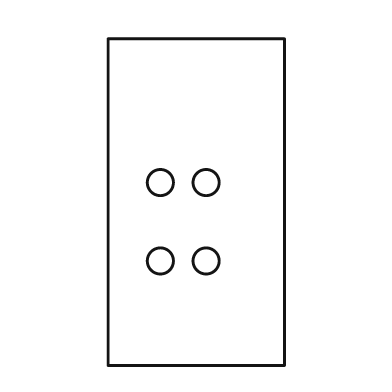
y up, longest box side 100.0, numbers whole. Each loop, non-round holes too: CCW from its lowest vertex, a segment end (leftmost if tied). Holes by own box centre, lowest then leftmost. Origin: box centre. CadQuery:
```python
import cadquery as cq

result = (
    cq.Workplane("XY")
    .moveTo(-27.0, -50.0)
    .lineTo(27.0, -50.0)
    .lineTo(27.0, 50.0)
    .lineTo(-27.0, 50.0)
    .close()
    .moveTo(-11.0, -18.0)
    .circle(4.0)
    .moveTo(3.0, -18.0)
    .circle(4.0)
    .moveTo(-11.0, 6.0)
    .circle(4.0)
    .moveTo(3.0, 6.0)
    .circle(4.0)
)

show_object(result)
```